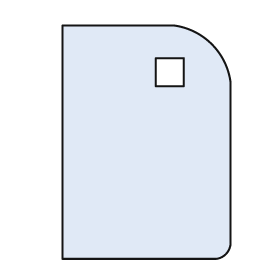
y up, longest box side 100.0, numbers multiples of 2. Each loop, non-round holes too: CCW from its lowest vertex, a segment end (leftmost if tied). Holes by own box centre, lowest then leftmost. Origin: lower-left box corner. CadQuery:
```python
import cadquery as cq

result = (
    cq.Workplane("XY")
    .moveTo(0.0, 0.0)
    .lineTo(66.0, 0.0)
    .threePointArc((70.0, 2.0), (72.0, 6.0))
    .lineTo(72.0, 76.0)
    .threePointArc((64.0, 92.0), (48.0, 100.0))
    .lineTo(0.0, 100.0)
    .close()
    .moveTo(40.0, 74.0)
    .lineTo(52.0, 74.0)
    .lineTo(52.0, 86.0)
    .lineTo(40.0, 86.0)
    .close()
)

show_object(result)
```